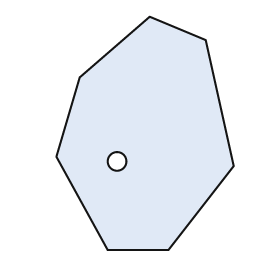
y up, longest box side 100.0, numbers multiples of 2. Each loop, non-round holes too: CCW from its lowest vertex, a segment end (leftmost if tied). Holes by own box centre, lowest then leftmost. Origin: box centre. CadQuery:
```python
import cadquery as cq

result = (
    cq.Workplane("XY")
    .moveTo(-16.0, -50.0)
    .lineTo(10.0, -50.0)
    .lineTo(38.0, -14.0)
    .lineTo(26.0, 40.0)
    .lineTo(2.0, 50.0)
    .lineTo(-28.0, 24.0)
    .lineTo(-38.0, -10.0)
    .close()
    .moveTo(-12.0, -12.0)
    .circle(4.0)
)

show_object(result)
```